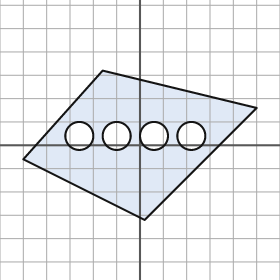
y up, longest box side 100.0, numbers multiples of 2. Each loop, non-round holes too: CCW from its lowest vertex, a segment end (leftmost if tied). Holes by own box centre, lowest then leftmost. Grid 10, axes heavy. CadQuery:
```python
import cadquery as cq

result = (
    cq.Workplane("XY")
    .moveTo(2.0, -32.0)
    .lineTo(50.0, 16.0)
    .lineTo(-16.0, 32.0)
    .lineTo(-50.0, -6.0)
    .close()
    .moveTo(-26.0, 4.0)
    .circle(6.0)
    .moveTo(-10.0, 4.0)
    .circle(6.0)
    .moveTo(6.0, 4.0)
    .circle(6.0)
    .moveTo(22.0, 4.0)
    .circle(6.0)
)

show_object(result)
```